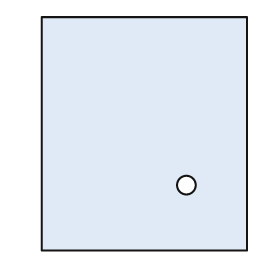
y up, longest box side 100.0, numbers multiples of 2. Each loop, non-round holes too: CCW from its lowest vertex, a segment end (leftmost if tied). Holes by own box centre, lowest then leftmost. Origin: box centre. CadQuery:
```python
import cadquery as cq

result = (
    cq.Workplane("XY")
    .moveTo(-44.0, -50.0)
    .lineTo(44.0, -50.0)
    .lineTo(44.0, 50.0)
    .lineTo(-44.0, 50.0)
    .close()
    .moveTo(18.0, -22.0)
    .circle(4.0)
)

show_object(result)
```